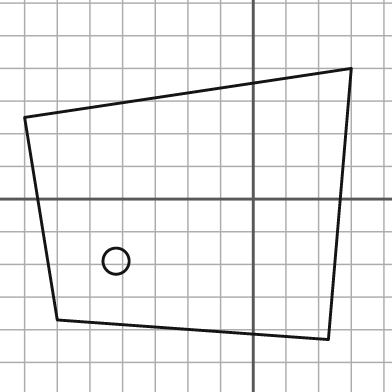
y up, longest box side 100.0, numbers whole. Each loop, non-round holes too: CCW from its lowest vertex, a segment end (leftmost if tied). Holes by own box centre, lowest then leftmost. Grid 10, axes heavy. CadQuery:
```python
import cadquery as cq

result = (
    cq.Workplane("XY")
    .moveTo(23.0, -43.0)
    .lineTo(30.0, 40.0)
    .lineTo(-70.0, 25.0)
    .lineTo(-60.0, -37.0)
    .close()
    .moveTo(-42.0, -19.0)
    .circle(4.0)
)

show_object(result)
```